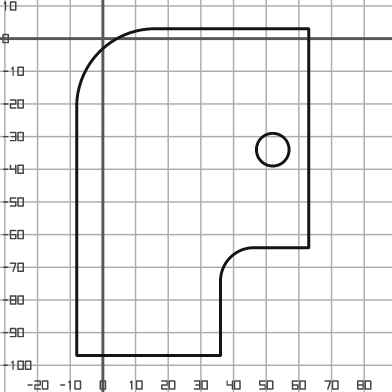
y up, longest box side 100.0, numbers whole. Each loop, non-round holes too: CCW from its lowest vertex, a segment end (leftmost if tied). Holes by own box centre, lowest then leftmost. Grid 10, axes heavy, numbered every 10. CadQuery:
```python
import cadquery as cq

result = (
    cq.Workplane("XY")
    .moveTo(-8.0, -97.0)
    .lineTo(36.0, -97.0)
    .lineTo(36.0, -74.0)
    .threePointArc((39.0, -67.0), (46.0, -64.0))
    .lineTo(63.0, -64.0)
    .lineTo(63.0, 3.0)
    .lineTo(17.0, 3.0)
    .threePointArc((-1.0, -4.0), (-8.0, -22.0))
    .close()
    .moveTo(52.0, -34.0)
    .circle(5.0)
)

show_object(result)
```